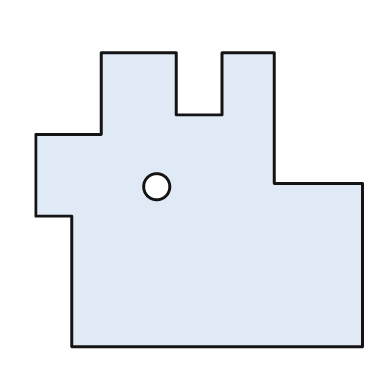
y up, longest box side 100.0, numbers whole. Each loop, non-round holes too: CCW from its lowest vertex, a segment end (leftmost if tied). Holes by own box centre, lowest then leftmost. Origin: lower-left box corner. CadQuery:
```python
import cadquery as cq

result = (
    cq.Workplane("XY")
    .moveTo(11.0, 0.0)
    .lineTo(100.0, 0.0)
    .lineTo(100.0, 50.0)
    .lineTo(73.0, 50.0)
    .lineTo(73.0, 90.0)
    .lineTo(57.0, 90.0)
    .lineTo(57.0, 71.0)
    .lineTo(43.0, 71.0)
    .lineTo(43.0, 90.0)
    .lineTo(20.0, 90.0)
    .lineTo(20.0, 65.0)
    .lineTo(0.0, 65.0)
    .lineTo(0.0, 40.0)
    .lineTo(11.0, 40.0)
    .close()
    .moveTo(37.0, 49.0)
    .circle(4.0)
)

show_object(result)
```